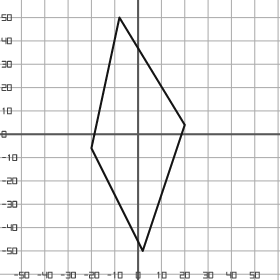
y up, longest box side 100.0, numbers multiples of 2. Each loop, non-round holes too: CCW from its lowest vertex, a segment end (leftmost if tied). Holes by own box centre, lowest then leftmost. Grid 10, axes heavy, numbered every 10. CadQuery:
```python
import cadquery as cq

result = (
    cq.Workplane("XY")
    .moveTo(2.0, -50.0)
    .lineTo(20.0, 4.0)
    .lineTo(-8.0, 50.0)
    .lineTo(-20.0, -6.0)
    .close()
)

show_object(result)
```